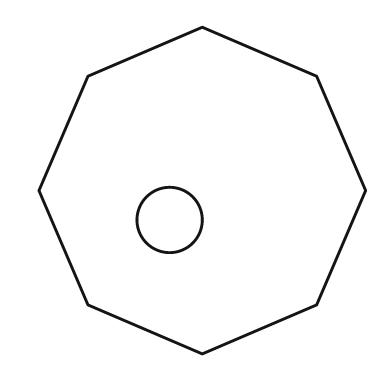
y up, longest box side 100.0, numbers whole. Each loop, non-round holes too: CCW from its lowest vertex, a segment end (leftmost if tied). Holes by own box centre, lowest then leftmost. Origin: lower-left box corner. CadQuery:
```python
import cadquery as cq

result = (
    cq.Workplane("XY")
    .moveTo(50.0, 0.0)
    .lineTo(85.0, 15.0)
    .lineTo(100.0, 50.0)
    .lineTo(85.0, 85.0)
    .lineTo(50.0, 100.0)
    .lineTo(15.0, 85.0)
    .lineTo(0.0, 50.0)
    .lineTo(15.0, 15.0)
    .close()
    .moveTo(40.0, 41.0)
    .circle(10.0)
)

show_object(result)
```